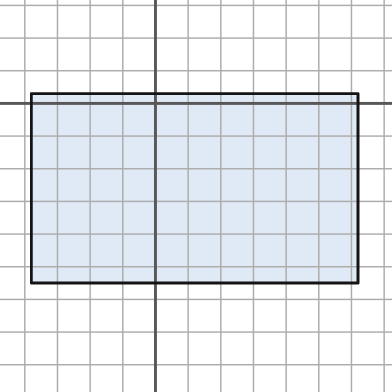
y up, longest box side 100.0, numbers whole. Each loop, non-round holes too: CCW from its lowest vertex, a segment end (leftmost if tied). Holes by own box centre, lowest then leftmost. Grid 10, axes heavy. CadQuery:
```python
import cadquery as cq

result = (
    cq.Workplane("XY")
    .moveTo(-38.0, -55.0)
    .lineTo(62.0, -55.0)
    .lineTo(62.0, 3.0)
    .lineTo(-38.0, 3.0)
    .close()
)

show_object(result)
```